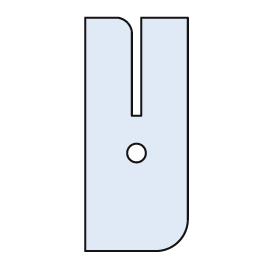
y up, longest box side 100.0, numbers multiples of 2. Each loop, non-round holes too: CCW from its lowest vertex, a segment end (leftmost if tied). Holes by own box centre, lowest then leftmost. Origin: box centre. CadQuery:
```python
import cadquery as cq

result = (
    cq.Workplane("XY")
    .moveTo(-22.0, -50.0)
    .lineTo(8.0, -50.0)
    .threePointArc((18.0, -46.0), (22.0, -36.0))
    .lineTo(22.0, 50.0)
    .lineTo(2.0, 50.0)
    .lineTo(2.0, 8.0)
    .lineTo(-2.0, 8.0)
    .lineTo(-2.0, 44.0)
    .threePointArc((-4.0, 48.0), (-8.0, 50.0))
    .lineTo(-22.0, 50.0)
    .close()
    .moveTo(0.0, -8.0)
    .circle(4.0)
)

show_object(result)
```